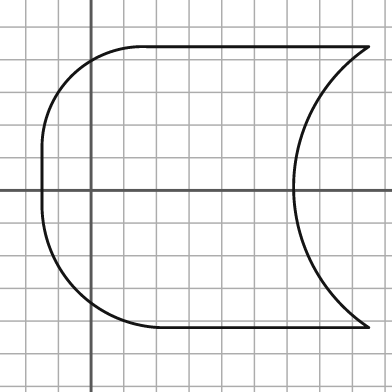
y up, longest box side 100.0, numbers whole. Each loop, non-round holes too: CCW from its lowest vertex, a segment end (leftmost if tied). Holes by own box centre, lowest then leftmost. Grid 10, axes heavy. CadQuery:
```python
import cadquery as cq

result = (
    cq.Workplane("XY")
    .moveTo(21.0, -42.0)
    .lineTo(85.0, -42.0)
    .threePointArc((62.0, 1.0), (85.0, 44.0))
    .lineTo(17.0, 44.0)
    .threePointArc((-6.0, 35.0), (-15.0, 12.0))
    .lineTo(-15.0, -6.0)
    .threePointArc((-4.0, -31.0), (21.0, -42.0))
    .close()
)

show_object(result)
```